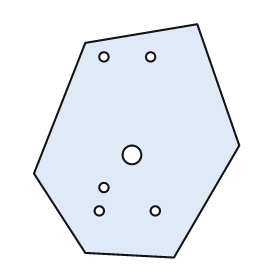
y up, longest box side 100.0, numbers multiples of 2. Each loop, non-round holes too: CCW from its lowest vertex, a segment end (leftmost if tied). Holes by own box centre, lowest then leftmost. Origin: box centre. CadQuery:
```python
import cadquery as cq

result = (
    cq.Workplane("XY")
    .moveTo(16.0, -50.0)
    .lineTo(44.0, -2.0)
    .lineTo(26.0, 50.0)
    .lineTo(-22.0, 42.0)
    .lineTo(-44.0, -14.0)
    .lineTo(-22.0, -48.0)
    .close()
    .moveTo(-16.0, -30.0)
    .circle(2.0)
    .moveTo(8.0, -30.0)
    .circle(2.0)
    .moveTo(-14.0, -20.0)
    .circle(2.0)
    .moveTo(-2.0, -6.0)
    .circle(4.0)
    .moveTo(-14.0, 36.0)
    .circle(2.0)
    .moveTo(6.0, 36.0)
    .circle(2.0)
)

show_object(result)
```